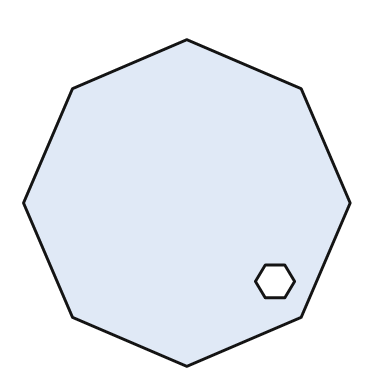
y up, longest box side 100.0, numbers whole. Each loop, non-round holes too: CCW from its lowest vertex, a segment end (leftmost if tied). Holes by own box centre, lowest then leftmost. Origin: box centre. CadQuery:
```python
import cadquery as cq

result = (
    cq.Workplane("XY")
    .moveTo(0.0, -50.0)
    .lineTo(35.0, -35.0)
    .lineTo(50.0, 0.0)
    .lineTo(35.0, 35.0)
    .lineTo(0.0, 50.0)
    .lineTo(-35.0, 35.0)
    .lineTo(-50.0, 0.0)
    .lineTo(-35.0, -35.0)
    .close()
    .moveTo(24.0, -29.0)
    .lineTo(30.0, -29.0)
    .lineTo(33.0, -24.0)
    .lineTo(30.0, -19.0)
    .lineTo(24.0, -19.0)
    .lineTo(21.0, -24.0)
    .close()
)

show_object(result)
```